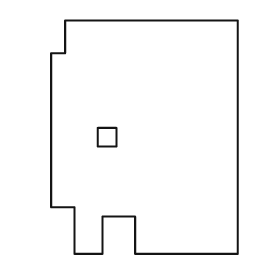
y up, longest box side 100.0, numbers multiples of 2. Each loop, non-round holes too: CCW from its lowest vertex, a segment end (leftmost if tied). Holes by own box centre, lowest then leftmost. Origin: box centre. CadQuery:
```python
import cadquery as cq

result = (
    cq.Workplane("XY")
    .moveTo(-30.0, -50.0)
    .lineTo(-18.0, -50.0)
    .lineTo(-18.0, -34.0)
    .lineTo(-4.0, -34.0)
    .lineTo(-4.0, -50.0)
    .lineTo(40.0, -50.0)
    .lineTo(40.0, 50.0)
    .lineTo(-34.0, 50.0)
    .lineTo(-34.0, 36.0)
    .lineTo(-40.0, 36.0)
    .lineTo(-40.0, -30.0)
    .lineTo(-30.0, -30.0)
    .close()
    .moveTo(-20.0, -4.0)
    .lineTo(-12.0, -4.0)
    .lineTo(-12.0, 4.0)
    .lineTo(-20.0, 4.0)
    .close()
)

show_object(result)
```